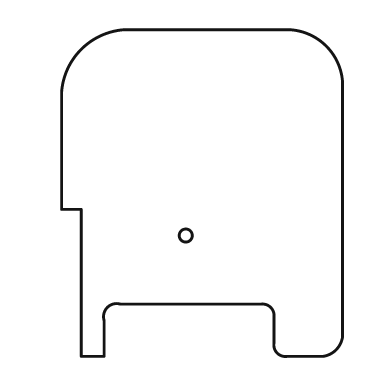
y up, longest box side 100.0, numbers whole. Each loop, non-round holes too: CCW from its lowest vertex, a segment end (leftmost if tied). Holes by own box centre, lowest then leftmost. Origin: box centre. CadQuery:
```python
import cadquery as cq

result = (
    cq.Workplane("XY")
    .moveTo(-37.0, -50.0)
    .lineTo(-30.0, -50.0)
    .lineTo(-30.0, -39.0)
    .threePointArc((-29.0, -35.0), (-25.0, -34.0))
    .lineTo(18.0, -34.0)
    .threePointArc((21.0, -35.0), (22.0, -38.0))
    .lineTo(22.0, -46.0)
    .threePointArc((23.0, -49.0), (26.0, -50.0))
    .lineTo(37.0, -50.0)
    .threePointArc((41.0, -48.0), (43.0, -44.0))
    .lineTo(43.0, 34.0)
    .threePointArc((38.0, 45.0), (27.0, 50.0))
    .lineTo(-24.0, 50.0)
    .threePointArc((-37.0, 44.0), (-43.0, 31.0))
    .lineTo(-43.0, -5.0)
    .lineTo(-37.0, -5.0)
    .close()
    .moveTo(-5.0, -13.0)
    .circle(2.0)
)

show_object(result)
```